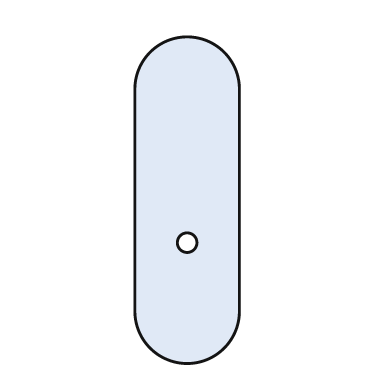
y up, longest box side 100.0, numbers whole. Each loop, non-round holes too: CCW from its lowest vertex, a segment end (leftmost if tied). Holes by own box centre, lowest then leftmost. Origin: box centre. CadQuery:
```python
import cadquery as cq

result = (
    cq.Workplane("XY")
    .moveTo(-16.0, -34.0)
    .threePointArc((0.0, -50.0), (16.0, -34.0))
    .lineTo(16.0, 34.0)
    .threePointArc((0.0, 50.0), (-16.0, 34.0))
    .close()
    .moveTo(0.0, -13.0)
    .circle(3.0)
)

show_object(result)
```